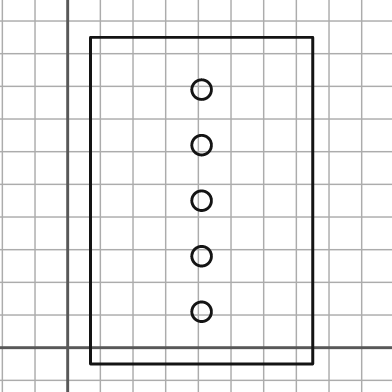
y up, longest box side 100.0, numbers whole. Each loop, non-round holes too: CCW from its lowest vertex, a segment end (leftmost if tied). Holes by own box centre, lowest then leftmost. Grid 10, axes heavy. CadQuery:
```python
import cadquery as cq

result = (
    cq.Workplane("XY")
    .moveTo(7.0, -5.0)
    .lineTo(75.0, -5.0)
    .lineTo(75.0, 95.0)
    .lineTo(7.0, 95.0)
    .close()
    .moveTo(41.0, 11.0)
    .circle(3.0)
    .moveTo(41.0, 28.0)
    .circle(3.0)
    .moveTo(41.0, 45.0)
    .circle(3.0)
    .moveTo(41.0, 62.0)
    .circle(3.0)
    .moveTo(41.0, 79.0)
    .circle(3.0)
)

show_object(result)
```